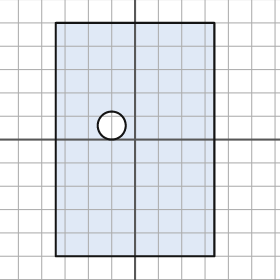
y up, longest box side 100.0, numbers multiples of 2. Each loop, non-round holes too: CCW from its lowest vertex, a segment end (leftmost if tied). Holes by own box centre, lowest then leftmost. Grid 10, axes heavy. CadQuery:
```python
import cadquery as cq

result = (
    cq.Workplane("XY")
    .moveTo(-34.0, -50.0)
    .lineTo(34.0, -50.0)
    .lineTo(34.0, 50.0)
    .lineTo(-34.0, 50.0)
    .close()
    .moveTo(-10.0, 6.0)
    .circle(6.0)
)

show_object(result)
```